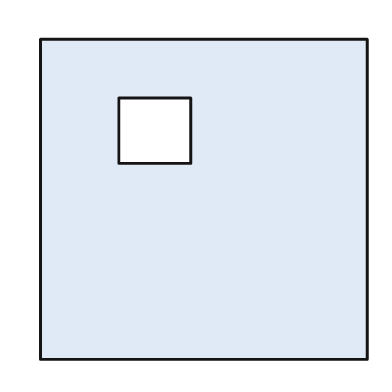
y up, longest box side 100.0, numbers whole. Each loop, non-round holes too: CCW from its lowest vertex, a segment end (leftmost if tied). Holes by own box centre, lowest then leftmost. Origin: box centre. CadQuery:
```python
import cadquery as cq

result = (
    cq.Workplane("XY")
    .moveTo(-50.0, -49.0)
    .lineTo(50.0, -49.0)
    .lineTo(50.0, 49.0)
    .lineTo(-50.0, 49.0)
    .close()
    .moveTo(-26.0, 11.0)
    .lineTo(-4.0, 11.0)
    .lineTo(-4.0, 31.0)
    .lineTo(-26.0, 31.0)
    .close()
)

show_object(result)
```